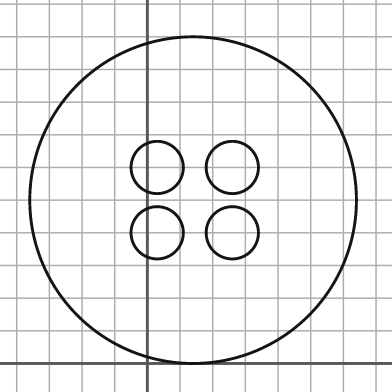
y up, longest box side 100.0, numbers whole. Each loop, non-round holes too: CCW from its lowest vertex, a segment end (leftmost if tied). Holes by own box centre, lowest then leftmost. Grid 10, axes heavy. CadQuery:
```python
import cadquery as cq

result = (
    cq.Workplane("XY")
    .moveTo(14.0, 50.0)
    .circle(50.0)
    .moveTo(3.0, 40.0)
    .circle(8.0)
    .moveTo(26.0, 40.0)
    .circle(8.0)
    .moveTo(3.0, 60.0)
    .circle(8.0)
    .moveTo(26.0, 60.0)
    .circle(8.0)
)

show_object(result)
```